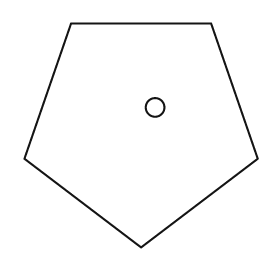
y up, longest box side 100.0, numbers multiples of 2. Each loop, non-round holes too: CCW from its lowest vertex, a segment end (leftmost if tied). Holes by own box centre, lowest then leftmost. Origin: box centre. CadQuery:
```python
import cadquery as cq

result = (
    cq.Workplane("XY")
    .moveTo(0.0, -48.0)
    .lineTo(50.0, -10.0)
    .lineTo(30.0, 48.0)
    .lineTo(-30.0, 48.0)
    .lineTo(-50.0, -10.0)
    .close()
    .moveTo(6.0, 12.0)
    .circle(4.0)
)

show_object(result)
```